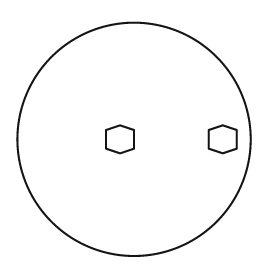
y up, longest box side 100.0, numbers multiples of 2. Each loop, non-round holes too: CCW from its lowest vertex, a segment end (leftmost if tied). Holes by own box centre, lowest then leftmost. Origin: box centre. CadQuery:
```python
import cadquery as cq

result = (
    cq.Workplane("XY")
    .moveTo(0.0, 0.0)
    .circle(50.0)
    .moveTo(-6.0, -6.0)
    .lineTo(0.0, -4.0)
    .lineTo(0.0, 4.0)
    .lineTo(-6.0, 6.0)
    .lineTo(-12.0, 4.0)
    .lineTo(-12.0, -4.0)
    .close()
    .moveTo(38.0, -6.0)
    .lineTo(44.0, -4.0)
    .lineTo(44.0, 4.0)
    .lineTo(38.0, 6.0)
    .lineTo(32.0, 4.0)
    .lineTo(32.0, -4.0)
    .close()
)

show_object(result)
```